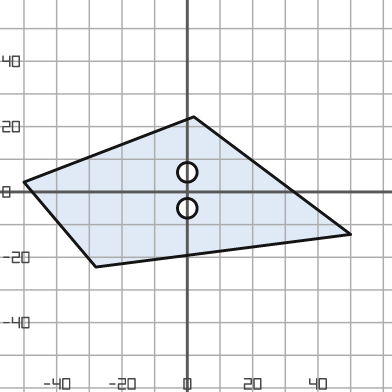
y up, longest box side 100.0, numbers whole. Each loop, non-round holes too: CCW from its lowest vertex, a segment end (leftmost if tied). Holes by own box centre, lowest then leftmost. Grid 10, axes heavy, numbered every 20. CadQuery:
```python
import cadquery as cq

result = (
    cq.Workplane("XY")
    .moveTo(-28.0, -23.0)
    .lineTo(50.0, -13.0)
    .lineTo(2.0, 23.0)
    .lineTo(-50.0, 3.0)
    .close()
    .moveTo(0.0, -5.0)
    .circle(3.0)
    .moveTo(0.0, 6.0)
    .circle(3.0)
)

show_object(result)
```